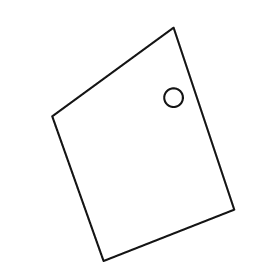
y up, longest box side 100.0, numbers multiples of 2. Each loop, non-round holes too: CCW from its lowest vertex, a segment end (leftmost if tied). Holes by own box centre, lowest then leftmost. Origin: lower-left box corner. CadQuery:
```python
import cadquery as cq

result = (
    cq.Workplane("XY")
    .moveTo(22.0, 0.0)
    .lineTo(78.0, 22.0)
    .lineTo(52.0, 100.0)
    .lineTo(0.0, 62.0)
    .close()
    .moveTo(52.0, 70.0)
    .circle(4.0)
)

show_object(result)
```